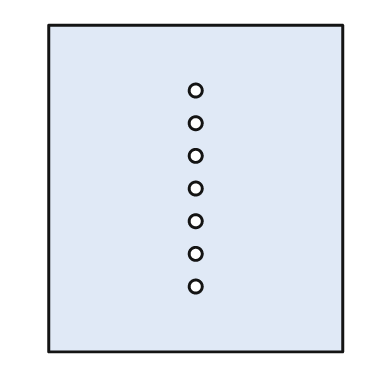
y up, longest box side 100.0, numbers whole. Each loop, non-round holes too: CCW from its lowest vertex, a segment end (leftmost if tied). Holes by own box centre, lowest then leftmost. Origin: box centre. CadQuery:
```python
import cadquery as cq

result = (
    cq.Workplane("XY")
    .moveTo(-45.0, -50.0)
    .lineTo(45.0, -50.0)
    .lineTo(45.0, 50.0)
    .lineTo(-45.0, 50.0)
    .close()
    .moveTo(0.0, -30.0)
    .circle(2.0)
    .moveTo(0.0, -20.0)
    .circle(2.0)
    .moveTo(0.0, -10.0)
    .circle(2.0)
    .moveTo(0.0, 0.0)
    .circle(2.0)
    .moveTo(0.0, 10.0)
    .circle(2.0)
    .moveTo(0.0, 20.0)
    .circle(2.0)
    .moveTo(0.0, 30.0)
    .circle(2.0)
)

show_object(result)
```